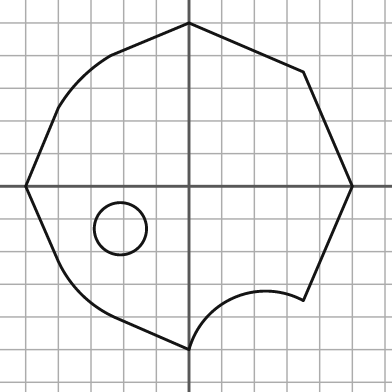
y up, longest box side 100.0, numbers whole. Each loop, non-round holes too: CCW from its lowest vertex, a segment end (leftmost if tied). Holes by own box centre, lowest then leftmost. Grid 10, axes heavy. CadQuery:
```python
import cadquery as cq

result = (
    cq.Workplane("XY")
    .moveTo(0.0, -50.0)
    .threePointArc((14.0, -34.0), (35.0, -35.0))
    .lineTo(50.0, 0.0)
    .lineTo(35.0, 35.0)
    .lineTo(0.0, 50.0)
    .lineTo(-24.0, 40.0)
    .threePointArc((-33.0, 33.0), (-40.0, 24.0))
    .lineTo(-50.0, 0.0)
    .lineTo(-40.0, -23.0)
    .threePointArc((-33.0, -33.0), (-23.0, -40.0))
    .close()
    .moveTo(-21.0, -13.0)
    .circle(8.0)
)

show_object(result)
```